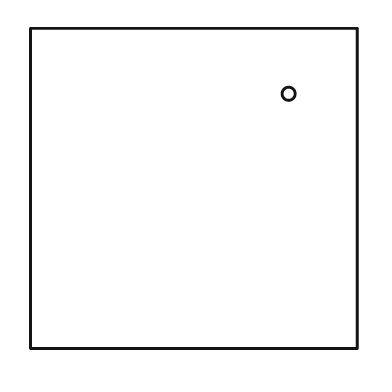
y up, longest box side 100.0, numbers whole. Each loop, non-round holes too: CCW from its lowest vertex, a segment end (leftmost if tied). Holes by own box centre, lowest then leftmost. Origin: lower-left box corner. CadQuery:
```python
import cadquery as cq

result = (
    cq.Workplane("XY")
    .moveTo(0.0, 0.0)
    .lineTo(100.0, 0.0)
    .lineTo(100.0, 98.0)
    .lineTo(0.0, 98.0)
    .close()
    .moveTo(79.0, 78.0)
    .circle(2.0)
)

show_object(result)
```